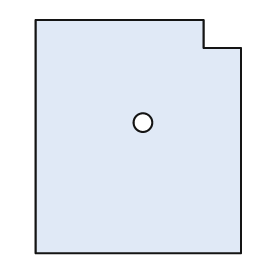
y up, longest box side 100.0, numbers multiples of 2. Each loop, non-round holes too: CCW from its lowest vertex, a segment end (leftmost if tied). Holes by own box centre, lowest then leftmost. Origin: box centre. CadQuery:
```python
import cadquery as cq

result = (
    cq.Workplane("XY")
    .moveTo(-44.0, -50.0)
    .lineTo(44.0, -50.0)
    .lineTo(44.0, 38.0)
    .lineTo(28.0, 38.0)
    .lineTo(28.0, 50.0)
    .lineTo(-44.0, 50.0)
    .close()
    .moveTo(2.0, 6.0)
    .circle(4.0)
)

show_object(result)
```